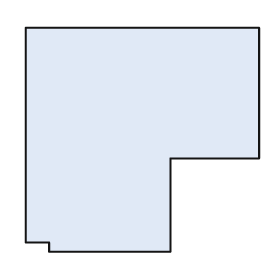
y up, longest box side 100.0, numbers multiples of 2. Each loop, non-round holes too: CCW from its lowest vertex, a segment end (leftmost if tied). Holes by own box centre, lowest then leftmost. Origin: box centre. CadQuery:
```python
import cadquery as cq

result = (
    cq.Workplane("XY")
    .moveTo(-40.0, -48.0)
    .lineTo(12.0, -48.0)
    .lineTo(12.0, -8.0)
    .lineTo(50.0, -8.0)
    .lineTo(50.0, 48.0)
    .lineTo(-50.0, 48.0)
    .lineTo(-50.0, -44.0)
    .lineTo(-40.0, -44.0)
    .close()
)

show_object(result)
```